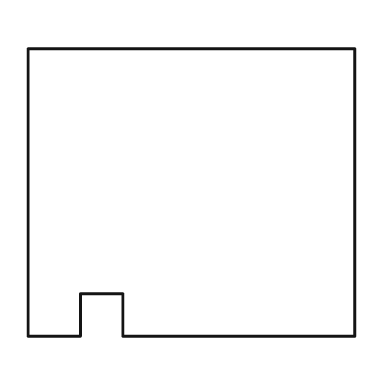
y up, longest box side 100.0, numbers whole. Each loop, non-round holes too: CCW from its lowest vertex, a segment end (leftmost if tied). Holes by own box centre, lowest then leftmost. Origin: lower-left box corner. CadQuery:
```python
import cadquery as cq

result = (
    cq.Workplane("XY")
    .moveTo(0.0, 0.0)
    .lineTo(16.0, 0.0)
    .lineTo(16.0, 13.0)
    .lineTo(29.0, 13.0)
    .lineTo(29.0, 0.0)
    .lineTo(100.0, 0.0)
    .lineTo(100.0, 88.0)
    .lineTo(0.0, 88.0)
    .close()
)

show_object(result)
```